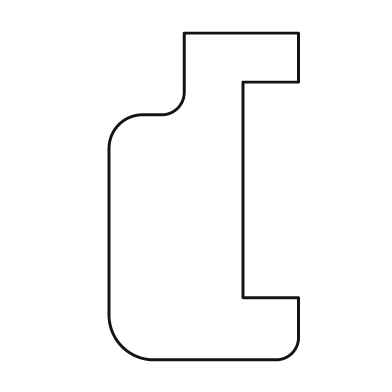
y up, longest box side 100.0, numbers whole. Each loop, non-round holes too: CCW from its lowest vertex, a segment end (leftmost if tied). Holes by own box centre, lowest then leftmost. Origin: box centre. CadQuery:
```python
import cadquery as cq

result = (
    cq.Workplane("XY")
    .moveTo(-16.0, -50.0)
    .lineTo(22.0, -50.0)
    .threePointArc((27.0, -48.0), (29.0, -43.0))
    .lineTo(29.0, -31.0)
    .lineTo(12.0, -31.0)
    .lineTo(12.0, 35.0)
    .lineTo(29.0, 35.0)
    .lineTo(29.0, 50.0)
    .lineTo(-6.0, 50.0)
    .lineTo(-6.0, 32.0)
    .threePointArc((-8.0, 27.0), (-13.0, 25.0))
    .lineTo(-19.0, 25.0)
    .threePointArc((-26.0, 22.0), (-29.0, 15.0))
    .lineTo(-29.0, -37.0)
    .threePointArc((-25.0, -46.0), (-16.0, -50.0))
    .close()
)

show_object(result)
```